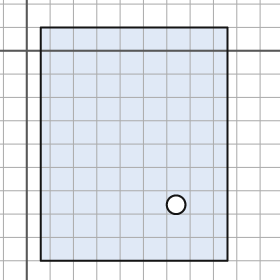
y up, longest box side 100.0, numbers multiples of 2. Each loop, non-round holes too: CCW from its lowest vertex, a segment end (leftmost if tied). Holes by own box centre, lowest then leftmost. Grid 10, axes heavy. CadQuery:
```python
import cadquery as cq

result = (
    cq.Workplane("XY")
    .moveTo(6.0, -90.0)
    .lineTo(86.0, -90.0)
    .lineTo(86.0, 10.0)
    .lineTo(6.0, 10.0)
    .close()
    .moveTo(64.0, -66.0)
    .circle(4.0)
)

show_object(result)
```